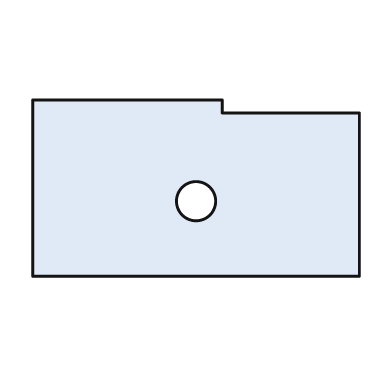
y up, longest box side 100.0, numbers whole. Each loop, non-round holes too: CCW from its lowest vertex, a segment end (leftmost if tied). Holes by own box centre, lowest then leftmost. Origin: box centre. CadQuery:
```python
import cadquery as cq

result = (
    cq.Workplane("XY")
    .moveTo(-50.0, -27.0)
    .lineTo(50.0, -27.0)
    .lineTo(50.0, 23.0)
    .lineTo(8.0, 23.0)
    .lineTo(8.0, 27.0)
    .lineTo(-50.0, 27.0)
    .close()
    .moveTo(0.0, -4.0)
    .circle(6.0)
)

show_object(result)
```